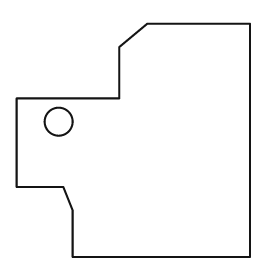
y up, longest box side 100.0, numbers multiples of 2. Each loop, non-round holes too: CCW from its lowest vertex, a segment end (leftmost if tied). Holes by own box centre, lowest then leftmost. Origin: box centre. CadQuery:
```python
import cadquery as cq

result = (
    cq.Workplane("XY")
    .moveTo(-26.0, -50.0)
    .lineTo(50.0, -50.0)
    .lineTo(50.0, 50.0)
    .lineTo(6.0, 50.0)
    .lineTo(-6.0, 40.0)
    .lineTo(-6.0, 18.0)
    .lineTo(-50.0, 18.0)
    .lineTo(-50.0, -20.0)
    .lineTo(-30.0, -20.0)
    .lineTo(-26.0, -30.0)
    .close()
    .moveTo(-32.0, 8.0)
    .circle(6.0)
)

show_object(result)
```